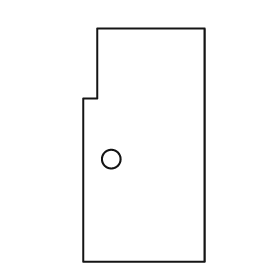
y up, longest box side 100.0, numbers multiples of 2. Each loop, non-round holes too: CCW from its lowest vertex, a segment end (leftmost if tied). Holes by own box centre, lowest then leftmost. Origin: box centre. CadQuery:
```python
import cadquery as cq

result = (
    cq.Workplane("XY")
    .moveTo(-26.0, -50.0)
    .lineTo(26.0, -50.0)
    .lineTo(26.0, 50.0)
    .lineTo(-20.0, 50.0)
    .lineTo(-20.0, 20.0)
    .lineTo(-26.0, 20.0)
    .close()
    .moveTo(-14.0, -6.0)
    .circle(4.0)
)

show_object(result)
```